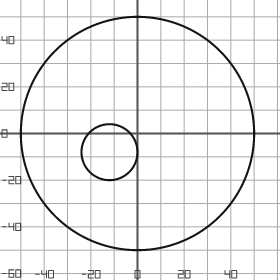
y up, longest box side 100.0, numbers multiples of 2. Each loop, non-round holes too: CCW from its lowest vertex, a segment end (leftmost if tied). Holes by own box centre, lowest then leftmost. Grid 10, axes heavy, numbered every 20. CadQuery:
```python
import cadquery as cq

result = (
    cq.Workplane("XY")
    .moveTo(0.0, 0.0)
    .circle(50.0)
    .moveTo(-12.0, -8.0)
    .circle(12.0)
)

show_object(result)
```